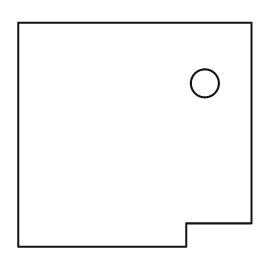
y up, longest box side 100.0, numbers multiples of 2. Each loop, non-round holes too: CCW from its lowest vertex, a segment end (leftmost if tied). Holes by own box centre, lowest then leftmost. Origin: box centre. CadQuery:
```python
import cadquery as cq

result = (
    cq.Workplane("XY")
    .moveTo(-50.0, -48.0)
    .lineTo(22.0, -48.0)
    .lineTo(22.0, -38.0)
    .lineTo(50.0, -38.0)
    .lineTo(50.0, 48.0)
    .lineTo(-50.0, 48.0)
    .close()
    .moveTo(30.0, 22.0)
    .circle(6.0)
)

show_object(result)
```